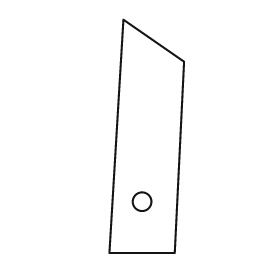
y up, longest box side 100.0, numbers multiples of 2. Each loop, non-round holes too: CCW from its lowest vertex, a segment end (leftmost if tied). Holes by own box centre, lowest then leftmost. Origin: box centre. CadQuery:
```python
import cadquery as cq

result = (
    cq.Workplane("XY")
    .moveTo(-16.0, -50.0)
    .lineTo(12.0, -50.0)
    .lineTo(16.0, 32.0)
    .lineTo(-10.0, 50.0)
    .close()
    .moveTo(-2.0, -28.0)
    .circle(4.0)
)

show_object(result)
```